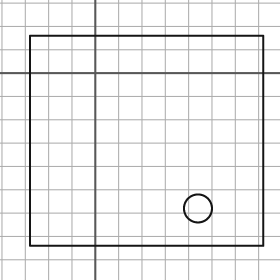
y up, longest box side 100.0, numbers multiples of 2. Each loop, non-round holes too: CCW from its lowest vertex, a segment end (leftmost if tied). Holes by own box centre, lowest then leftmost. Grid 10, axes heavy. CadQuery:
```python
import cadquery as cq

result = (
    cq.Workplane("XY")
    .moveTo(-28.0, -74.0)
    .lineTo(72.0, -74.0)
    .lineTo(72.0, 16.0)
    .lineTo(-28.0, 16.0)
    .close()
    .moveTo(44.0, -58.0)
    .circle(6.0)
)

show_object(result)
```